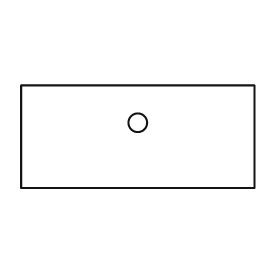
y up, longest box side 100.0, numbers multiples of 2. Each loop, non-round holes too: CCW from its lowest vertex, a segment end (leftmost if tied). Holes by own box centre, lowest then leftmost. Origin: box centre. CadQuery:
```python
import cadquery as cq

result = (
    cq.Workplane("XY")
    .moveTo(-50.0, -22.0)
    .lineTo(50.0, -22.0)
    .lineTo(50.0, 22.0)
    .lineTo(-50.0, 22.0)
    .close()
    .moveTo(0.0, 6.0)
    .circle(4.0)
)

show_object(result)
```